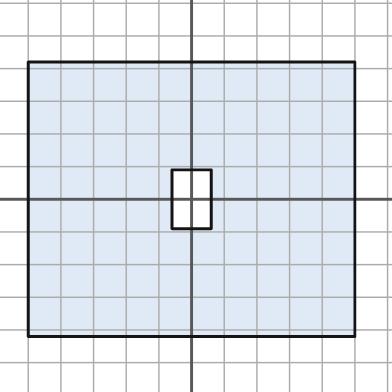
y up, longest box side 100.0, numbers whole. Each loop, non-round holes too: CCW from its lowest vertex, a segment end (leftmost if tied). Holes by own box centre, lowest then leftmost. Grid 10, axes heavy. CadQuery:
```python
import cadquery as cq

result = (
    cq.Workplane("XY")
    .moveTo(-50.0, -42.0)
    .lineTo(50.0, -42.0)
    .lineTo(50.0, 42.0)
    .lineTo(-50.0, 42.0)
    .close()
    .moveTo(-6.0, -9.0)
    .lineTo(6.0, -9.0)
    .lineTo(6.0, 9.0)
    .lineTo(-6.0, 9.0)
    .close()
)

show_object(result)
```